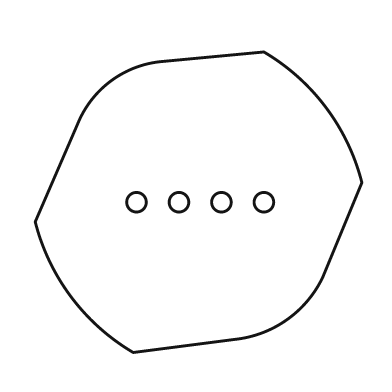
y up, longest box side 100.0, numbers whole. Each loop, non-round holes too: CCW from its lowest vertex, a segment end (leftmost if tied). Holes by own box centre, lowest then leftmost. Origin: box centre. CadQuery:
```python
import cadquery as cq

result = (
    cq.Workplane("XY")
    .moveTo(-20.0, -46.0)
    .lineTo(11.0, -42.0)
    .threePointArc((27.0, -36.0), (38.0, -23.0))
    .lineTo(50.0, 6.0)
    .threePointArc((39.0, 29.0), (20.0, 46.0))
    .lineTo(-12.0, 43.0)
    .threePointArc((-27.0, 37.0), (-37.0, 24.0))
    .lineTo(-50.0, -6.0)
    .threePointArc((-39.0, -29.0), (-20.0, -46.0))
    .close()
    .moveTo(-19.0, 0.0)
    .circle(3.0)
    .moveTo(-6.0, 0.0)
    .circle(3.0)
    .moveTo(7.0, 0.0)
    .circle(3.0)
    .moveTo(20.0, 0.0)
    .circle(3.0)
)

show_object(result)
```